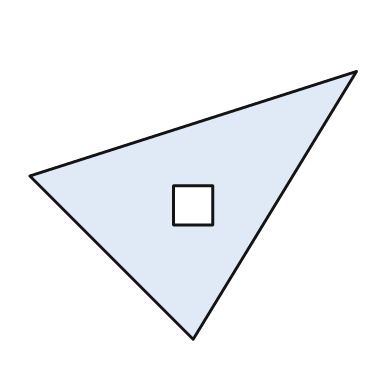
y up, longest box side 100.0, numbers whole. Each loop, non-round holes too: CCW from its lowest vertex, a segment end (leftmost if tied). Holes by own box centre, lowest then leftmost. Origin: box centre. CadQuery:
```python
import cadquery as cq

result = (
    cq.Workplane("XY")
    .moveTo(0.0, -41.0)
    .lineTo(50.0, 41.0)
    .lineTo(-50.0, 9.0)
    .close()
    .moveTo(-6.0, -6.0)
    .lineTo(6.0, -6.0)
    .lineTo(6.0, 6.0)
    .lineTo(-6.0, 6.0)
    .close()
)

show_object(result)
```